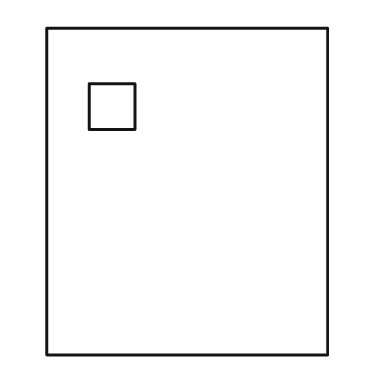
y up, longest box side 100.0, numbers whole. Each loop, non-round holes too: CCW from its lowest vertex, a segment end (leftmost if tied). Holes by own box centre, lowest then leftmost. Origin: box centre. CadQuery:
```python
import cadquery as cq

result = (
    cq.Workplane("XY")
    .moveTo(-43.0, -50.0)
    .lineTo(43.0, -50.0)
    .lineTo(43.0, 50.0)
    .lineTo(-43.0, 50.0)
    .close()
    .moveTo(-30.0, 19.0)
    .lineTo(-16.0, 19.0)
    .lineTo(-16.0, 33.0)
    .lineTo(-30.0, 33.0)
    .close()
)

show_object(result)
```